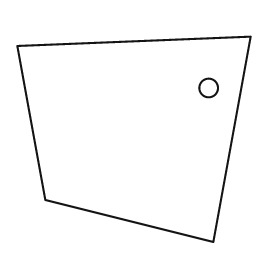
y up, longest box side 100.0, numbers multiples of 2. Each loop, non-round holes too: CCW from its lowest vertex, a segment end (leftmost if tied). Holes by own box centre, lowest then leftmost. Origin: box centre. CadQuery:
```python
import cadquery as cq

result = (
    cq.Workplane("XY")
    .moveTo(34.0, -44.0)
    .lineTo(50.0, 44.0)
    .lineTo(-50.0, 40.0)
    .lineTo(-38.0, -26.0)
    .close()
    .moveTo(32.0, 22.0)
    .circle(4.0)
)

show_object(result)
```